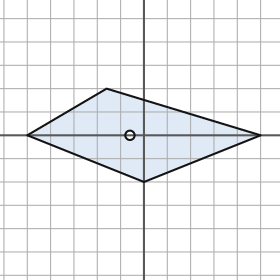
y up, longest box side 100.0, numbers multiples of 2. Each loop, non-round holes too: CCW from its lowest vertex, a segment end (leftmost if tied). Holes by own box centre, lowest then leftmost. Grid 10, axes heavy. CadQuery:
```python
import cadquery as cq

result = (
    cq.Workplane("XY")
    .moveTo(0.0, -20.0)
    .lineTo(50.0, 0.0)
    .lineTo(-16.0, 20.0)
    .lineTo(-50.0, 0.0)
    .close()
    .moveTo(-6.0, 0.0)
    .circle(2.0)
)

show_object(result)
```